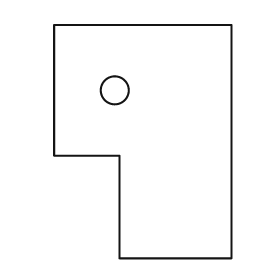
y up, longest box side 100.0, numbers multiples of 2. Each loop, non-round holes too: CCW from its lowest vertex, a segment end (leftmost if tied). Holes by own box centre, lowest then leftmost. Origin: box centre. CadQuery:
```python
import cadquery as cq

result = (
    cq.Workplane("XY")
    .moveTo(-10.0, -50.0)
    .lineTo(38.0, -50.0)
    .lineTo(38.0, 50.0)
    .lineTo(-38.0, 50.0)
    .lineTo(-38.0, -6.0)
    .lineTo(-10.0, -6.0)
    .close()
    .moveTo(-12.0, 22.0)
    .circle(6.0)
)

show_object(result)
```